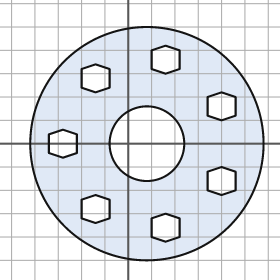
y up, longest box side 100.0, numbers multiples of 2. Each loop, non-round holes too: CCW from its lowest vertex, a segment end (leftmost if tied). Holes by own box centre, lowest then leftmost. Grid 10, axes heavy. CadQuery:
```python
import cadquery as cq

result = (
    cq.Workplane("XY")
    .moveTo(8.0, 0.0)
    .circle(50.0)
    .moveTo(16.0, -42.0)
    .lineTo(22.0, -40.0)
    .lineTo(22.0, -32.0)
    .lineTo(16.0, -30.0)
    .lineTo(10.0, -32.0)
    .lineTo(10.0, -40.0)
    .close()
    .moveTo(-14.0, -34.0)
    .lineTo(-8.0, -32.0)
    .lineTo(-8.0, -24.0)
    .lineTo(-14.0, -22.0)
    .lineTo(-20.0, -24.0)
    .lineTo(-20.0, -32.0)
    .close()
    .moveTo(40.0, -22.0)
    .lineTo(46.0, -20.0)
    .lineTo(46.0, -12.0)
    .lineTo(40.0, -10.0)
    .lineTo(34.0, -12.0)
    .lineTo(34.0, -20.0)
    .close()
    .moveTo(-28.0, -6.0)
    .lineTo(-22.0, -4.0)
    .lineTo(-22.0, 4.0)
    .lineTo(-28.0, 6.0)
    .lineTo(-34.0, 4.0)
    .lineTo(-34.0, -4.0)
    .close()
    .moveTo(8.0, 0.0)
    .circle(16.0)
    .moveTo(40.0, 10.0)
    .lineTo(46.0, 12.0)
    .lineTo(46.0, 20.0)
    .lineTo(40.0, 22.0)
    .lineTo(34.0, 20.0)
    .lineTo(34.0, 12.0)
    .close()
    .moveTo(-14.0, 22.0)
    .lineTo(-8.0, 24.0)
    .lineTo(-8.0, 32.0)
    .lineTo(-14.0, 34.0)
    .lineTo(-20.0, 32.0)
    .lineTo(-20.0, 24.0)
    .close()
    .moveTo(16.0, 30.0)
    .lineTo(22.0, 32.0)
    .lineTo(22.0, 40.0)
    .lineTo(16.0, 42.0)
    .lineTo(10.0, 40.0)
    .lineTo(10.0, 32.0)
    .close()
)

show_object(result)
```